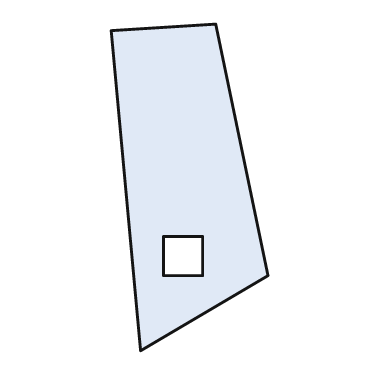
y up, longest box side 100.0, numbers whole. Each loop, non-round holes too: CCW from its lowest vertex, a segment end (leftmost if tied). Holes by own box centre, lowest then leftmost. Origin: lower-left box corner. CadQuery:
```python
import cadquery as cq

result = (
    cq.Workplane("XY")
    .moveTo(9.0, 0.0)
    .lineTo(48.0, 23.0)
    .lineTo(32.0, 100.0)
    .lineTo(0.0, 98.0)
    .close()
    .moveTo(16.0, 23.0)
    .lineTo(28.0, 23.0)
    .lineTo(28.0, 35.0)
    .lineTo(16.0, 35.0)
    .close()
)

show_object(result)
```